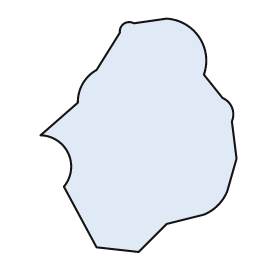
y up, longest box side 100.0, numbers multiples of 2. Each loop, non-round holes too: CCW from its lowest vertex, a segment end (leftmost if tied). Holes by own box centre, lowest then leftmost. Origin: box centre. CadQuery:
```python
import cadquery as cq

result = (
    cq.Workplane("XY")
    .moveTo(0.0, -50.0)
    .lineTo(12.0, -38.0)
    .lineTo(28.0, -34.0)
    .threePointArc((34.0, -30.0), (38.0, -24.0))
    .lineTo(42.0, -10.0)
    .lineTo(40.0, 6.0)
    .threePointArc((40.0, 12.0), (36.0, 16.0))
    .lineTo(28.0, 26.0)
    .threePointArc((26.0, 42.0), (12.0, 50.0))
    .lineTo(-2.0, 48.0)
    .threePointArc((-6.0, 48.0), (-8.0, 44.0))
    .lineTo(-18.0, 28.0)
    .threePointArc((-24.0, 22.0), (-26.0, 14.0))
    .lineTo(-42.0, 0.0)
    .threePointArc((-30.0, -8.0), (-32.0, -22.0))
    .lineTo(-18.0, -48.0)
    .close()
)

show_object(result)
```